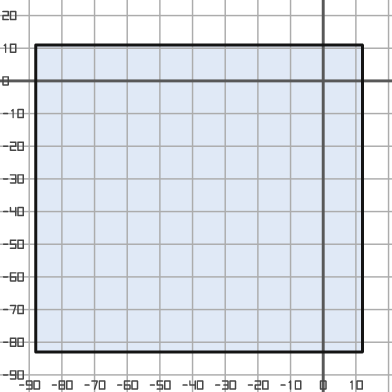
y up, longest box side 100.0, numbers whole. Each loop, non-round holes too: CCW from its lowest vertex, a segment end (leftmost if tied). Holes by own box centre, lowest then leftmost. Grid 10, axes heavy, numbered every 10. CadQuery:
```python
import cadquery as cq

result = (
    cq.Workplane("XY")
    .moveTo(-88.0, -83.0)
    .lineTo(12.0, -83.0)
    .lineTo(12.0, 11.0)
    .lineTo(-88.0, 11.0)
    .close()
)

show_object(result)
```